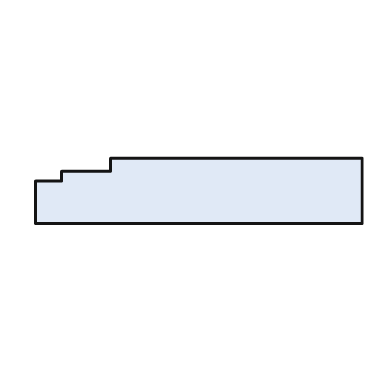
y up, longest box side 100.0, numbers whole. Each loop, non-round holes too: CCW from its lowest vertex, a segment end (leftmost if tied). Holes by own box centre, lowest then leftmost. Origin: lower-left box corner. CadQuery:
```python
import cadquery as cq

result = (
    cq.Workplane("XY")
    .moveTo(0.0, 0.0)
    .lineTo(100.0, 0.0)
    .lineTo(100.0, 20.0)
    .lineTo(23.0, 20.0)
    .lineTo(23.0, 16.0)
    .lineTo(8.0, 16.0)
    .lineTo(8.0, 13.0)
    .lineTo(0.0, 13.0)
    .close()
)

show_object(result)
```